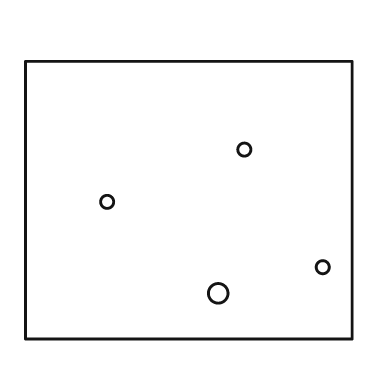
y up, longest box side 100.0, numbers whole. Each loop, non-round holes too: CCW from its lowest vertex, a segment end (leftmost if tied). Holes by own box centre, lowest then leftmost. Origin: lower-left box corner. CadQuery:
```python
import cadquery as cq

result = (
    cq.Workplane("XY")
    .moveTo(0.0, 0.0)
    .lineTo(100.0, 0.0)
    .lineTo(100.0, 85.0)
    .lineTo(0.0, 85.0)
    .close()
    .moveTo(59.0, 14.0)
    .circle(3.0)
    .moveTo(91.0, 22.0)
    .circle(2.0)
    .moveTo(25.0, 42.0)
    .circle(2.0)
    .moveTo(67.0, 58.0)
    .circle(2.0)
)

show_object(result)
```